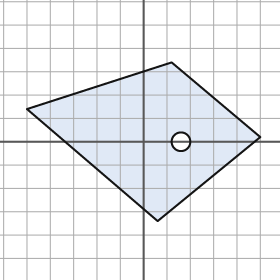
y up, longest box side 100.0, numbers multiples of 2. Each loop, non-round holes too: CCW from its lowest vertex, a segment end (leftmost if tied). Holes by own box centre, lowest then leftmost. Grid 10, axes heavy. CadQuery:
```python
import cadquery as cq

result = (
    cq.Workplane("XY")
    .moveTo(6.0, -34.0)
    .lineTo(50.0, 2.0)
    .lineTo(12.0, 34.0)
    .lineTo(-50.0, 14.0)
    .close()
    .moveTo(16.0, 0.0)
    .circle(4.0)
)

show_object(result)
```